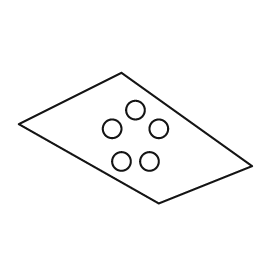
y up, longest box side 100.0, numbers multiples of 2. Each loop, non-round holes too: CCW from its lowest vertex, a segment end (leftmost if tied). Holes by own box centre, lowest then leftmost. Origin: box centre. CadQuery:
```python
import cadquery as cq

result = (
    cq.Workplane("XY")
    .moveTo(10.0, -28.0)
    .lineTo(50.0, -12.0)
    .lineTo(-6.0, 28.0)
    .lineTo(-50.0, 6.0)
    .close()
    .moveTo(-6.0, -10.0)
    .circle(4.0)
    .moveTo(6.0, -10.0)
    .circle(4.0)
    .moveTo(-10.0, 4.0)
    .circle(4.0)
    .moveTo(10.0, 4.0)
    .circle(4.0)
    .moveTo(0.0, 12.0)
    .circle(4.0)
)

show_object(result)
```